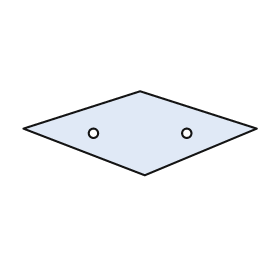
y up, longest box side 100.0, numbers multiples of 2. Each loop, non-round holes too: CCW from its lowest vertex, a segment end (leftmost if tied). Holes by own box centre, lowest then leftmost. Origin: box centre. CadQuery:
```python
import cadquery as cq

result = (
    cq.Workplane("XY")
    .moveTo(2.0, -18.0)
    .lineTo(50.0, 2.0)
    .lineTo(0.0, 18.0)
    .lineTo(-50.0, 2.0)
    .close()
    .moveTo(-20.0, 0.0)
    .circle(2.0)
    .moveTo(20.0, 0.0)
    .circle(2.0)
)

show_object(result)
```